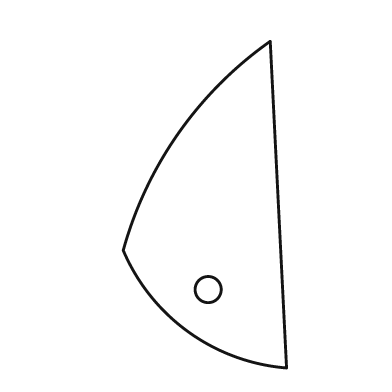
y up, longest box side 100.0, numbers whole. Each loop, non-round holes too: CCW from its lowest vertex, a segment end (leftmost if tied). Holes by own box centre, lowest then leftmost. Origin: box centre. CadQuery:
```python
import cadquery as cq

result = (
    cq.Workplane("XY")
    .moveTo(25.0, -50.0)
    .lineTo(20.0, 50.0)
    .threePointArc((-8.0, 22.0), (-25.0, -14.0))
    .threePointArc((-5.0, -39.0), (25.0, -50.0))
    .close()
    .moveTo(1.0, -26.0)
    .circle(4.0)
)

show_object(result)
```